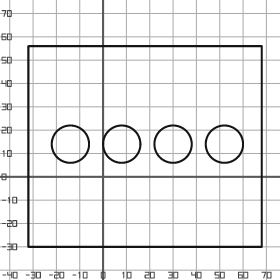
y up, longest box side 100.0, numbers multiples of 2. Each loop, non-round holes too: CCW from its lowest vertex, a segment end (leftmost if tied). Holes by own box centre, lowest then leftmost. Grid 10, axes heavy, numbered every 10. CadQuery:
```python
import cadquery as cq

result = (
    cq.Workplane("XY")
    .moveTo(-32.0, -30.0)
    .lineTo(68.0, -30.0)
    .lineTo(68.0, 56.0)
    .lineTo(-32.0, 56.0)
    .close()
    .moveTo(-14.0, 14.0)
    .circle(8.0)
    .moveTo(8.0, 14.0)
    .circle(8.0)
    .moveTo(30.0, 14.0)
    .circle(8.0)
    .moveTo(52.0, 14.0)
    .circle(8.0)
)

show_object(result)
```